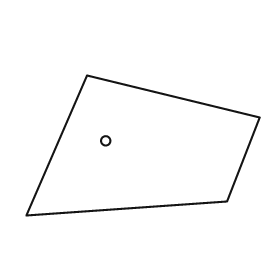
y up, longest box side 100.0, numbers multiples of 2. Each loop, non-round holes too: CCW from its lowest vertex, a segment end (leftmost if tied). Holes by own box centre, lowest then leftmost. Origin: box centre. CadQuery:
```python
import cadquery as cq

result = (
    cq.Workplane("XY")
    .moveTo(-50.0, -30.0)
    .lineTo(36.0, -24.0)
    .lineTo(50.0, 12.0)
    .lineTo(-24.0, 30.0)
    .close()
    .moveTo(-16.0, 2.0)
    .circle(2.0)
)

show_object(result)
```